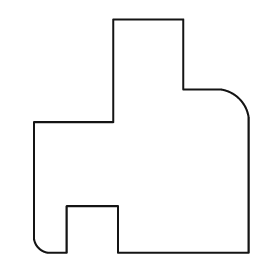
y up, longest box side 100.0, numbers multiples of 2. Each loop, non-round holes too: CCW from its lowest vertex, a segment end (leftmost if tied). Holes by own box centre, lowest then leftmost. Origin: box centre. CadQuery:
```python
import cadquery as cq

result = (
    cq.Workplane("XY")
    .moveTo(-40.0, -50.0)
    .lineTo(-32.0, -50.0)
    .lineTo(-32.0, -30.0)
    .lineTo(-10.0, -30.0)
    .lineTo(-10.0, -50.0)
    .lineTo(46.0, -50.0)
    .lineTo(46.0, 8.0)
    .threePointArc((42.0, 16.0), (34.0, 20.0))
    .lineTo(18.0, 20.0)
    .lineTo(18.0, 50.0)
    .lineTo(-12.0, 50.0)
    .lineTo(-12.0, 6.0)
    .lineTo(-46.0, 6.0)
    .lineTo(-46.0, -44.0)
    .threePointArc((-44.0, -48.0), (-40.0, -50.0))
    .close()
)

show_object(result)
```